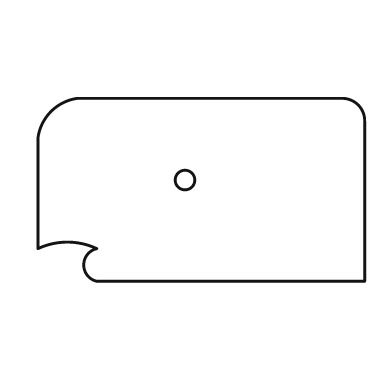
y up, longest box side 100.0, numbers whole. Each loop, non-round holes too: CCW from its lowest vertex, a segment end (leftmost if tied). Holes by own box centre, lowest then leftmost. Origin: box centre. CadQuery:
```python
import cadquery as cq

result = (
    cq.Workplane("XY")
    .moveTo(-32.0, -28.0)
    .lineTo(50.0, -28.0)
    .lineTo(50.0, 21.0)
    .threePointArc((48.0, 26.0), (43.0, 28.0))
    .lineTo(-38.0, 28.0)
    .threePointArc((-46.0, 24.0), (-50.0, 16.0))
    .lineTo(-50.0, -18.0)
    .threePointArc((-41.0, -16.0), (-32.0, -18.0))
    .threePointArc((-36.0, -23.0), (-32.0, -28.0))
    .close()
    .moveTo(-5.0, 3.0)
    .circle(3.0)
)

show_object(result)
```